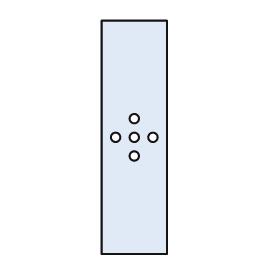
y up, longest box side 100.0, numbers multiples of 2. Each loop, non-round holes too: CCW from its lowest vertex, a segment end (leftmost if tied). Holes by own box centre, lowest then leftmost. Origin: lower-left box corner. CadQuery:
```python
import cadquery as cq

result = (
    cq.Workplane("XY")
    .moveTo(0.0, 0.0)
    .lineTo(28.0, 0.0)
    .lineTo(28.0, 100.0)
    .lineTo(0.0, 100.0)
    .close()
    .moveTo(14.0, 42.0)
    .circle(2.0)
    .moveTo(6.0, 50.0)
    .circle(2.0)
    .moveTo(14.0, 50.0)
    .circle(2.0)
    .moveTo(22.0, 50.0)
    .circle(2.0)
    .moveTo(14.0, 58.0)
    .circle(2.0)
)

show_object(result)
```